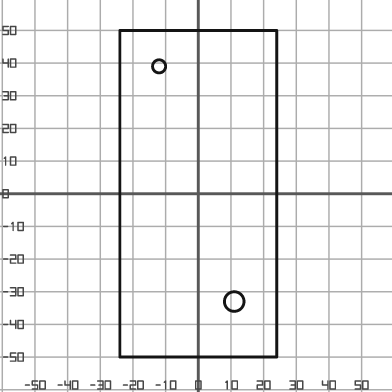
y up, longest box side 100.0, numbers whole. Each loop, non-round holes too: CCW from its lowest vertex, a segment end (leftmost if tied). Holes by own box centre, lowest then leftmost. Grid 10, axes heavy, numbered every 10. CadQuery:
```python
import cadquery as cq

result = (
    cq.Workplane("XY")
    .moveTo(-24.0, -50.0)
    .lineTo(24.0, -50.0)
    .lineTo(24.0, 50.0)
    .lineTo(-24.0, 50.0)
    .close()
    .moveTo(11.0, -33.0)
    .circle(3.0)
    .moveTo(-12.0, 39.0)
    .circle(2.0)
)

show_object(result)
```